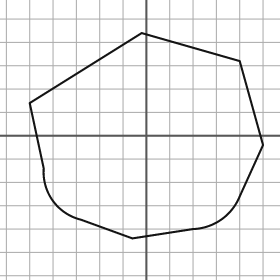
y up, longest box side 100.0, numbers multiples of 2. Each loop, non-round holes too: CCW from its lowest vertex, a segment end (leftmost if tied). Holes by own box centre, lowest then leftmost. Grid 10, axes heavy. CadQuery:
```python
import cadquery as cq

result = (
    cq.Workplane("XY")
    .moveTo(-6.0, -44.0)
    .lineTo(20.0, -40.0)
    .threePointArc((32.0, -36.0), (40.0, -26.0))
    .lineTo(50.0, -4.0)
    .lineTo(40.0, 32.0)
    .lineTo(-2.0, 44.0)
    .lineTo(-50.0, 14.0)
    .lineTo(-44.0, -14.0)
    .threePointArc((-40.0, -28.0), (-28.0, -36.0))
    .close()
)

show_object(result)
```